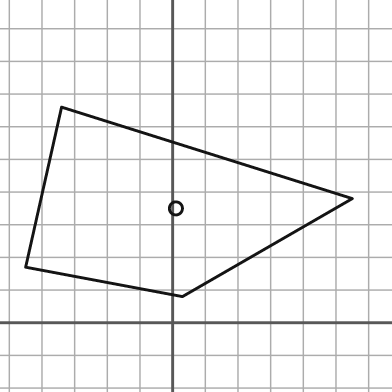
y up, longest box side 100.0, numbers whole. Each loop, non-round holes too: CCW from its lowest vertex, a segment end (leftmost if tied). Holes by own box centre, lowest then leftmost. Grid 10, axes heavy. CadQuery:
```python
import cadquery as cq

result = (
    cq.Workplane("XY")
    .moveTo(3.0, 8.0)
    .lineTo(55.0, 38.0)
    .lineTo(-34.0, 66.0)
    .lineTo(-45.0, 17.0)
    .close()
    .moveTo(1.0, 35.0)
    .circle(2.0)
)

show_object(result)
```